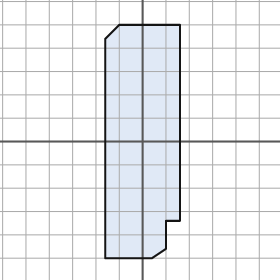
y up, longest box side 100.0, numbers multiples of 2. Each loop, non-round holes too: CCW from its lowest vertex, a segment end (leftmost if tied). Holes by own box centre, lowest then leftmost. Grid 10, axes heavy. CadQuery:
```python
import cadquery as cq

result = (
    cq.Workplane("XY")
    .moveTo(-16.0, -50.0)
    .lineTo(4.0, -50.0)
    .lineTo(10.0, -46.0)
    .lineTo(10.0, -34.0)
    .lineTo(16.0, -34.0)
    .lineTo(16.0, 50.0)
    .lineTo(-10.0, 50.0)
    .lineTo(-16.0, 44.0)
    .close()
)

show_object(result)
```